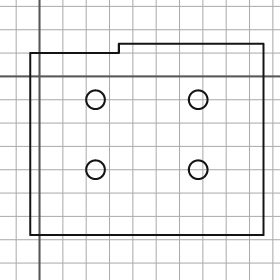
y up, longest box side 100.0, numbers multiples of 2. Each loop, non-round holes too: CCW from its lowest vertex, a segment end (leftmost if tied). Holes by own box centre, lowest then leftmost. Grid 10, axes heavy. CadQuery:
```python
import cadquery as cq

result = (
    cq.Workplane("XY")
    .moveTo(-4.0, -68.0)
    .lineTo(96.0, -68.0)
    .lineTo(96.0, 14.0)
    .lineTo(34.0, 14.0)
    .lineTo(34.0, 10.0)
    .lineTo(-4.0, 10.0)
    .close()
    .moveTo(24.0, -40.0)
    .circle(4.0)
    .moveTo(68.0, -40.0)
    .circle(4.0)
    .moveTo(24.0, -10.0)
    .circle(4.0)
    .moveTo(68.0, -10.0)
    .circle(4.0)
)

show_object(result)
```